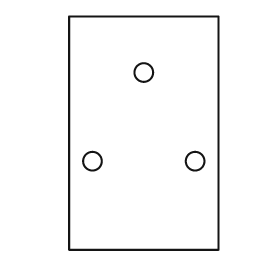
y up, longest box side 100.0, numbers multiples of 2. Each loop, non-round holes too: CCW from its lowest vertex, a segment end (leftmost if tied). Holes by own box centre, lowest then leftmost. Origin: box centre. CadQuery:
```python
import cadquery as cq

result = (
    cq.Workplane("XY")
    .moveTo(-32.0, -50.0)
    .lineTo(32.0, -50.0)
    .lineTo(32.0, 50.0)
    .lineTo(-32.0, 50.0)
    .close()
    .moveTo(-22.0, -12.0)
    .circle(4.0)
    .moveTo(22.0, -12.0)
    .circle(4.0)
    .moveTo(0.0, 26.0)
    .circle(4.0)
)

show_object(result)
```